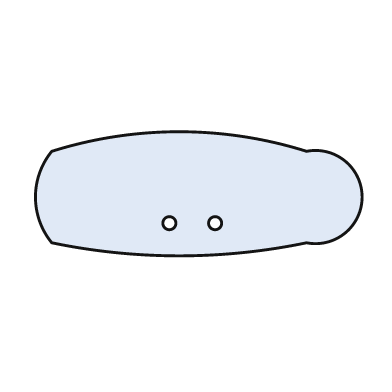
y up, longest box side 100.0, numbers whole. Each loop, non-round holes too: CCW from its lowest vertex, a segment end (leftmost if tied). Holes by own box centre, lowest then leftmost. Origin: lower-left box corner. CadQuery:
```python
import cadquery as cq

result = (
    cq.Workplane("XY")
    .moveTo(5.0, 4.0)
    .threePointArc((44.0, 0.0), (83.0, 4.0))
    .threePointArc((100.0, 18.0), (83.0, 32.0))
    .threePointArc((44.0, 38.0), (5.0, 32.0))
    .threePointArc((0.0, 18.0), (5.0, 4.0))
    .close()
    .moveTo(41.0, 10.0)
    .circle(2.0)
    .moveTo(55.0, 10.0)
    .circle(2.0)
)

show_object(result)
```